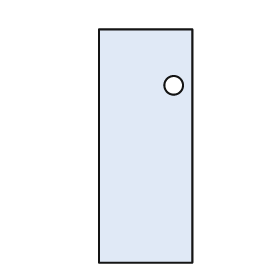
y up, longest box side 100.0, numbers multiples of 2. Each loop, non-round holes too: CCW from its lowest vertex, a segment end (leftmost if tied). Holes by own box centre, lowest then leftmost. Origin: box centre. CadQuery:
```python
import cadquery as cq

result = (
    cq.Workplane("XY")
    .moveTo(-20.0, -50.0)
    .lineTo(20.0, -50.0)
    .lineTo(20.0, 50.0)
    .lineTo(-20.0, 50.0)
    .close()
    .moveTo(12.0, 26.0)
    .circle(4.0)
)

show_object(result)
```